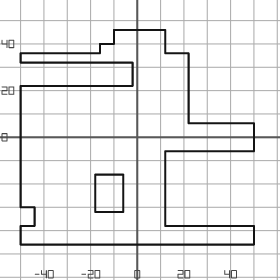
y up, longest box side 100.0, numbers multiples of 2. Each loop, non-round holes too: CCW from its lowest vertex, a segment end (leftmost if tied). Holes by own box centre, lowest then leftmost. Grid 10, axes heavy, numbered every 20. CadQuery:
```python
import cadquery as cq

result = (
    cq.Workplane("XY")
    .moveTo(-50.0, -46.0)
    .lineTo(50.0, -46.0)
    .lineTo(50.0, -38.0)
    .lineTo(12.0, -38.0)
    .lineTo(12.0, -6.0)
    .lineTo(50.0, -6.0)
    .lineTo(50.0, 6.0)
    .lineTo(22.0, 6.0)
    .lineTo(22.0, 36.0)
    .lineTo(12.0, 36.0)
    .lineTo(12.0, 46.0)
    .lineTo(-10.0, 46.0)
    .lineTo(-10.0, 40.0)
    .lineTo(-16.0, 40.0)
    .lineTo(-16.0, 36.0)
    .lineTo(-50.0, 36.0)
    .lineTo(-50.0, 32.0)
    .lineTo(-2.0, 32.0)
    .lineTo(-2.0, 22.0)
    .lineTo(-50.0, 22.0)
    .lineTo(-50.0, -30.0)
    .lineTo(-44.0, -30.0)
    .lineTo(-44.0, -38.0)
    .lineTo(-50.0, -38.0)
    .close()
    .moveTo(-18.0, -32.0)
    .lineTo(-6.0, -32.0)
    .lineTo(-6.0, -16.0)
    .lineTo(-18.0, -16.0)
    .close()
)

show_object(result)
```